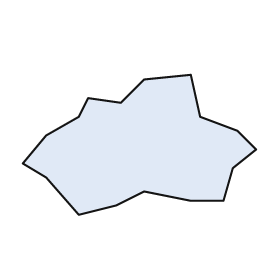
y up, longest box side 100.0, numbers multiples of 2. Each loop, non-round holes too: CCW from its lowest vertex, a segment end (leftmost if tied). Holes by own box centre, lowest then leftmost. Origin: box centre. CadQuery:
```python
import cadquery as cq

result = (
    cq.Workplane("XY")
    .moveTo(-26.0, -30.0)
    .lineTo(-10.0, -26.0)
    .lineTo(2.0, -20.0)
    .lineTo(22.0, -24.0)
    .lineTo(36.0, -24.0)
    .lineTo(40.0, -10.0)
    .lineTo(50.0, -2.0)
    .lineTo(42.0, 6.0)
    .lineTo(26.0, 12.0)
    .lineTo(22.0, 30.0)
    .lineTo(2.0, 28.0)
    .lineTo(-8.0, 18.0)
    .lineTo(-22.0, 20.0)
    .lineTo(-26.0, 12.0)
    .lineTo(-40.0, 4.0)
    .lineTo(-50.0, -8.0)
    .lineTo(-40.0, -14.0)
    .close()
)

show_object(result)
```